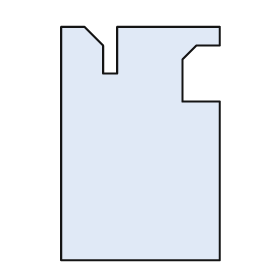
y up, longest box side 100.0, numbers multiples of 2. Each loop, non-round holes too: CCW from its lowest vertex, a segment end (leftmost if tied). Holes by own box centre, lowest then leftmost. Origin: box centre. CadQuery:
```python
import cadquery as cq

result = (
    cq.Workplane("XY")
    .moveTo(-34.0, -50.0)
    .lineTo(34.0, -50.0)
    .lineTo(34.0, 18.0)
    .lineTo(18.0, 18.0)
    .lineTo(18.0, 36.0)
    .lineTo(24.0, 42.0)
    .lineTo(34.0, 42.0)
    .lineTo(34.0, 50.0)
    .lineTo(-10.0, 50.0)
    .lineTo(-10.0, 30.0)
    .lineTo(-16.0, 30.0)
    .lineTo(-16.0, 42.0)
    .lineTo(-24.0, 50.0)
    .lineTo(-34.0, 50.0)
    .close()
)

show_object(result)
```